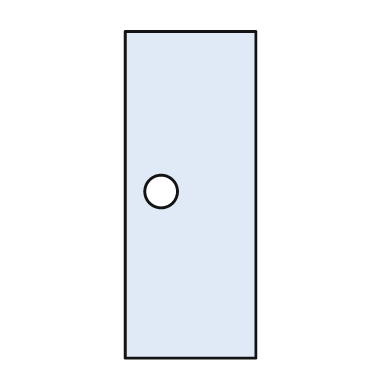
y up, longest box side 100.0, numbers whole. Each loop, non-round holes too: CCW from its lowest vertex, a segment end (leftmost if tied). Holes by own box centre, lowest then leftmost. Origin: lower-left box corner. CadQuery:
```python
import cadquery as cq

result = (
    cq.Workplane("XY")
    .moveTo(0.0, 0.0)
    .lineTo(40.0, 0.0)
    .lineTo(40.0, 100.0)
    .lineTo(0.0, 100.0)
    .close()
    .moveTo(11.0, 51.0)
    .circle(5.0)
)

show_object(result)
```